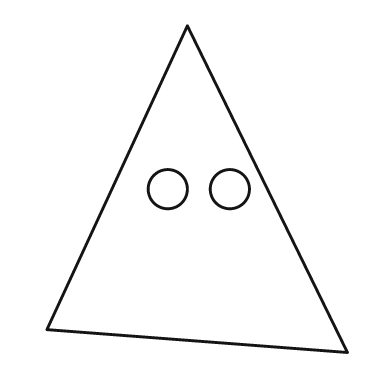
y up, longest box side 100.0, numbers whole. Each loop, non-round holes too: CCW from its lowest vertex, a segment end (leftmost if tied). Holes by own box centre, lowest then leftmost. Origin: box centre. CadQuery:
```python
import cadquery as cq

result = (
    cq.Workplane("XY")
    .moveTo(46.0, -50.0)
    .lineTo(-3.0, 50.0)
    .lineTo(-46.0, -43.0)
    .close()
    .moveTo(-9.0, 0.0)
    .circle(6.0)
    .moveTo(10.0, 0.0)
    .circle(6.0)
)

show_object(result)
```